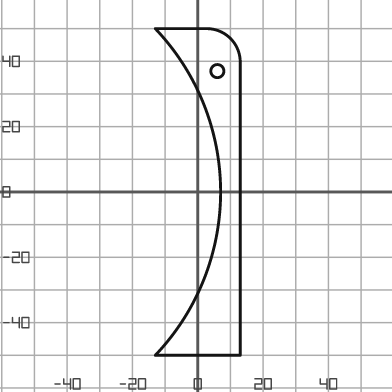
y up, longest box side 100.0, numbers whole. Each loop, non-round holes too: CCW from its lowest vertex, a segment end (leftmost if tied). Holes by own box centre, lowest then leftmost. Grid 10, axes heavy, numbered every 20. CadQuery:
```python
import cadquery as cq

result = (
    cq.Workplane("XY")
    .moveTo(-13.0, -50.0)
    .lineTo(13.0, -50.0)
    .lineTo(13.0, 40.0)
    .threePointArc((10.0, 47.0), (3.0, 50.0))
    .lineTo(-13.0, 50.0)
    .threePointArc((7.0, 0.0), (-13.0, -50.0))
    .close()
    .moveTo(6.0, 37.0)
    .circle(2.0)
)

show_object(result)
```